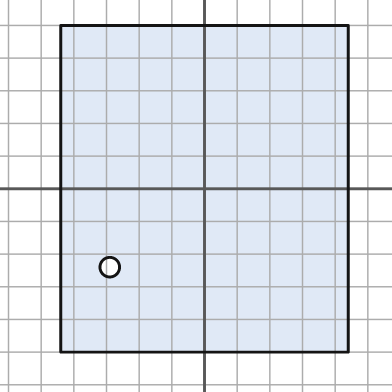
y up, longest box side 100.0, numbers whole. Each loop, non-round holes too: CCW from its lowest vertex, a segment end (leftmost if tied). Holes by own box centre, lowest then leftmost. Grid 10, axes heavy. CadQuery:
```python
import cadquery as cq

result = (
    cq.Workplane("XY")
    .moveTo(-44.0, -50.0)
    .lineTo(44.0, -50.0)
    .lineTo(44.0, 50.0)
    .lineTo(-44.0, 50.0)
    .close()
    .moveTo(-29.0, -24.0)
    .circle(3.0)
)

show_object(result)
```